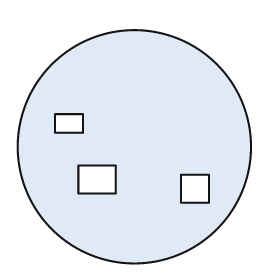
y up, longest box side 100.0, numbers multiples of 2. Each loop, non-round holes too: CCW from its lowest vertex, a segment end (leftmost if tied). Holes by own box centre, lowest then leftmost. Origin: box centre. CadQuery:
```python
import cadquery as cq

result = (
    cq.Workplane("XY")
    .moveTo(0.0, 0.0)
    .circle(50.0)
    .moveTo(20.0, -24.0)
    .lineTo(32.0, -24.0)
    .lineTo(32.0, -12.0)
    .lineTo(20.0, -12.0)
    .close()
    .moveTo(-24.0, -20.0)
    .lineTo(-8.0, -20.0)
    .lineTo(-8.0, -8.0)
    .lineTo(-24.0, -8.0)
    .close()
    .moveTo(-34.0, 6.0)
    .lineTo(-22.0, 6.0)
    .lineTo(-22.0, 14.0)
    .lineTo(-34.0, 14.0)
    .close()
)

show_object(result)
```